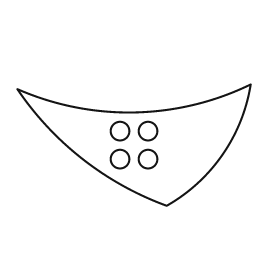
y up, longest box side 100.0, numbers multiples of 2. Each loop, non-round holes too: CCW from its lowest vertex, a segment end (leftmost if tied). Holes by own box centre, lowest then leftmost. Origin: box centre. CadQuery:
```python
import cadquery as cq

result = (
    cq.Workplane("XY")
    .moveTo(14.0, -26.0)
    .threePointArc((38.0, -4.0), (50.0, 26.0))
    .threePointArc((0.0, 14.0), (-50.0, 24.0))
    .threePointArc((-22.0, -6.0), (14.0, -26.0))
    .close()
    .moveTo(-6.0, -6.0)
    .circle(4.0)
    .moveTo(6.0, -6.0)
    .circle(4.0)
    .moveTo(-6.0, 6.0)
    .circle(4.0)
    .moveTo(6.0, 6.0)
    .circle(4.0)
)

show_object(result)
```